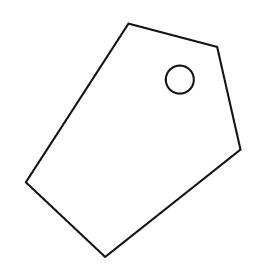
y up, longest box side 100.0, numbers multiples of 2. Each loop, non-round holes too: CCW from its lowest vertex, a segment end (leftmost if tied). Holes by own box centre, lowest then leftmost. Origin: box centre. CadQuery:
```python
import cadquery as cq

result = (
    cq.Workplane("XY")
    .moveTo(-12.0, -50.0)
    .lineTo(46.0, -4.0)
    .lineTo(36.0, 40.0)
    .lineTo(-2.0, 50.0)
    .lineTo(-46.0, -18.0)
    .close()
    .moveTo(20.0, 26.0)
    .circle(6.0)
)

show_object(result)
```